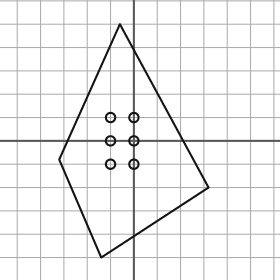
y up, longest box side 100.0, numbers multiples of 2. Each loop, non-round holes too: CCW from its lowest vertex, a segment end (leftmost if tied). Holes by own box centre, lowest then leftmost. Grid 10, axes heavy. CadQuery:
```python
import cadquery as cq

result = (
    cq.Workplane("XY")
    .moveTo(-14.0, -50.0)
    .lineTo(32.0, -20.0)
    .lineTo(-6.0, 50.0)
    .lineTo(-32.0, -8.0)
    .close()
    .moveTo(-10.0, -10.0)
    .circle(2.0)
    .moveTo(0.0, -10.0)
    .circle(2.0)
    .moveTo(-10.0, 0.0)
    .circle(2.0)
    .moveTo(0.0, 0.0)
    .circle(2.0)
    .moveTo(-10.0, 10.0)
    .circle(2.0)
    .moveTo(0.0, 10.0)
    .circle(2.0)
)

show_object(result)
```